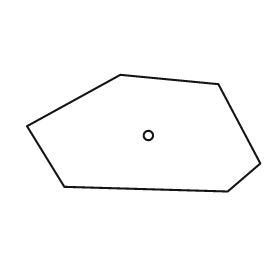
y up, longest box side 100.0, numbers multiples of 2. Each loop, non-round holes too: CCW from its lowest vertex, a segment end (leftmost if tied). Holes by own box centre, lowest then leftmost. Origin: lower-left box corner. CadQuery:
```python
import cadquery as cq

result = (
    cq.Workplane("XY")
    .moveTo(86.0, 0.0)
    .lineTo(100.0, 12.0)
    .lineTo(82.0, 46.0)
    .lineTo(40.0, 50.0)
    .lineTo(0.0, 28.0)
    .lineTo(16.0, 2.0)
    .close()
    .moveTo(52.0, 24.0)
    .circle(2.0)
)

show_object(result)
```